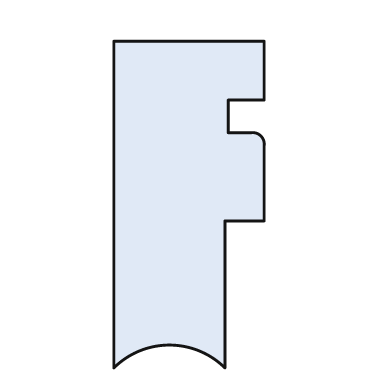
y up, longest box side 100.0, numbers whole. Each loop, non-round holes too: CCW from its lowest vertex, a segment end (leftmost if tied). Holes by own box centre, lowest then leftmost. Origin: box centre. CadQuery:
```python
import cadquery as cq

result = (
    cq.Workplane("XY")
    .moveTo(-23.0, -50.0)
    .threePointArc((-6.0, -43.0), (11.0, -50.0))
    .lineTo(11.0, -5.0)
    .lineTo(23.0, -5.0)
    .lineTo(23.0, 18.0)
    .threePointArc((22.0, 21.0), (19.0, 22.0))
    .lineTo(12.0, 22.0)
    .lineTo(12.0, 32.0)
    .lineTo(23.0, 32.0)
    .lineTo(23.0, 50.0)
    .lineTo(-23.0, 50.0)
    .close()
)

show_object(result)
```